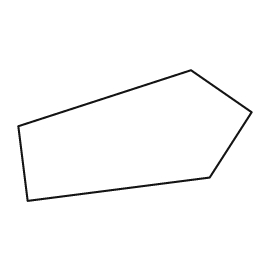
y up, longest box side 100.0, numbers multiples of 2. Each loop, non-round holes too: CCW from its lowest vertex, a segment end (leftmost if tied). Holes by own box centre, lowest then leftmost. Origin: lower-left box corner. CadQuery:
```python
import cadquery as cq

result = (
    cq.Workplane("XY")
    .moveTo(4.0, 0.0)
    .lineTo(82.0, 10.0)
    .lineTo(100.0, 38.0)
    .lineTo(74.0, 56.0)
    .lineTo(0.0, 32.0)
    .close()
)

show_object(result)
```